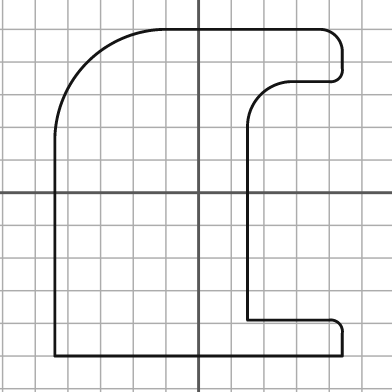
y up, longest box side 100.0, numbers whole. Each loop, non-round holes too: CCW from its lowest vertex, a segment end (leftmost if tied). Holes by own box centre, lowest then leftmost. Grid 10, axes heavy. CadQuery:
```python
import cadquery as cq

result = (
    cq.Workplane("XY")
    .moveTo(-44.0, -50.0)
    .lineTo(44.0, -50.0)
    .lineTo(44.0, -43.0)
    .threePointArc((43.0, -40.0), (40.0, -39.0))
    .lineTo(15.0, -39.0)
    .lineTo(15.0, 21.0)
    .threePointArc((19.0, 30.0), (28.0, 34.0))
    .lineTo(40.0, 34.0)
    .threePointArc((43.0, 35.0), (44.0, 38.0))
    .lineTo(44.0, 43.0)
    .threePointArc((42.0, 48.0), (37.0, 50.0))
    .lineTo(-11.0, 50.0)
    .threePointArc((-34.0, 40.0), (-44.0, 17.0))
    .close()
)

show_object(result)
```